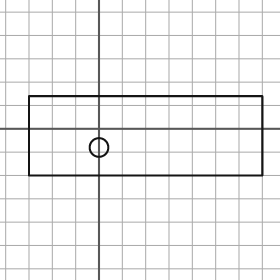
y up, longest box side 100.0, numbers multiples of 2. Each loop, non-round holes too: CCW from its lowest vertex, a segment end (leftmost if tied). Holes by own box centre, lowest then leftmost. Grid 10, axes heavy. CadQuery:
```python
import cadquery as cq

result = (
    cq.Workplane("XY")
    .moveTo(-30.0, -20.0)
    .lineTo(70.0, -20.0)
    .lineTo(70.0, 14.0)
    .lineTo(-30.0, 14.0)
    .close()
    .moveTo(0.0, -8.0)
    .circle(4.0)
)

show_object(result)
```